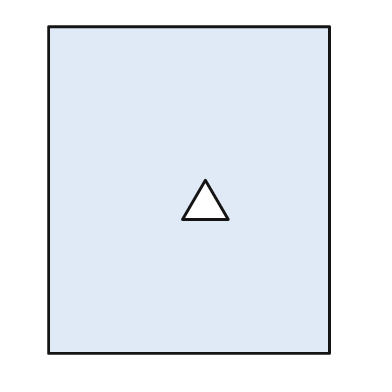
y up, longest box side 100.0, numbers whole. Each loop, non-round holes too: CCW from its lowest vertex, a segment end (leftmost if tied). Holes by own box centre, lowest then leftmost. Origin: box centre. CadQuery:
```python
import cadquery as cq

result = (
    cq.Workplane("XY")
    .moveTo(-43.0, -50.0)
    .lineTo(43.0, -50.0)
    .lineTo(43.0, 50.0)
    .lineTo(-43.0, 50.0)
    .close()
    .moveTo(-2.0, -9.0)
    .lineTo(12.0, -9.0)
    .lineTo(5.0, 3.0)
    .close()
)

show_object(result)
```